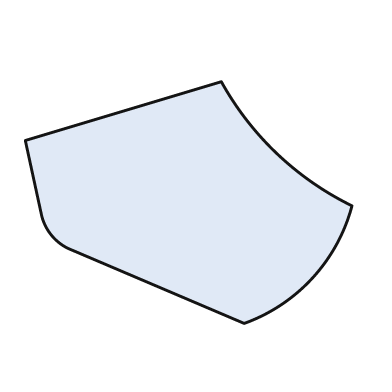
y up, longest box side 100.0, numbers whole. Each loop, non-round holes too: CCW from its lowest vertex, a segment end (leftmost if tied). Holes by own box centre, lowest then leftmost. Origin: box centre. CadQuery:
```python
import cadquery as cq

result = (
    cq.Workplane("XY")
    .moveTo(17.0, -37.0)
    .threePointArc((38.0, -23.0), (50.0, -1.0))
    .threePointArc((27.0, 15.0), (10.0, 37.0))
    .lineTo(-50.0, 19.0)
    .lineTo(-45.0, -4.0)
    .threePointArc((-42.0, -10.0), (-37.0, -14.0))
    .close()
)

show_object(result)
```